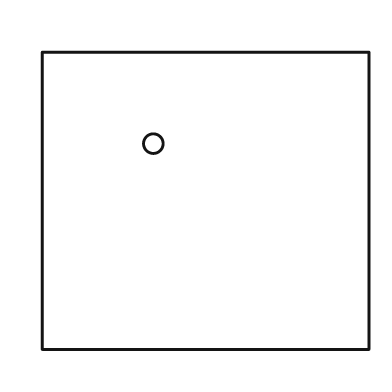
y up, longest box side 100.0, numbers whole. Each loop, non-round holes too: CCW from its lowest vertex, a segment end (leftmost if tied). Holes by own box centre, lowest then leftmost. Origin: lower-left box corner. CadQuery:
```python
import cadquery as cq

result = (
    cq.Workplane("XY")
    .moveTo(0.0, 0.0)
    .lineTo(100.0, 0.0)
    .lineTo(100.0, 91.0)
    .lineTo(0.0, 91.0)
    .close()
    .moveTo(34.0, 63.0)
    .circle(3.0)
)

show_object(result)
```